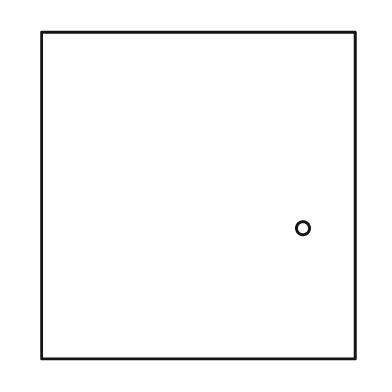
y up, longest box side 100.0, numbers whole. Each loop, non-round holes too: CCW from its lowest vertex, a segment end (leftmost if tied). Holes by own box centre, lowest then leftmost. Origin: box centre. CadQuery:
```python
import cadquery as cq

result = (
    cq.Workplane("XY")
    .moveTo(-48.0, -50.0)
    .lineTo(48.0, -50.0)
    .lineTo(48.0, 50.0)
    .lineTo(-48.0, 50.0)
    .close()
    .moveTo(32.0, -10.0)
    .circle(2.0)
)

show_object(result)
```